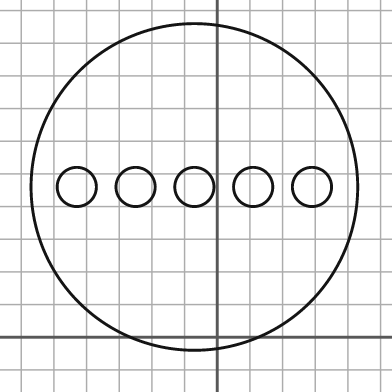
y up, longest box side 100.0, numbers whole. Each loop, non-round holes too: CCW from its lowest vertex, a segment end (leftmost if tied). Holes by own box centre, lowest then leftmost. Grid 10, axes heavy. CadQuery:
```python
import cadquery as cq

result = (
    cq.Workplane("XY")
    .moveTo(-7.0, 46.0)
    .circle(50.0)
    .moveTo(-43.0, 46.0)
    .circle(6.0)
    .moveTo(-25.0, 46.0)
    .circle(6.0)
    .moveTo(-7.0, 46.0)
    .circle(6.0)
    .moveTo(11.0, 46.0)
    .circle(6.0)
    .moveTo(29.0, 46.0)
    .circle(6.0)
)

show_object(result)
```